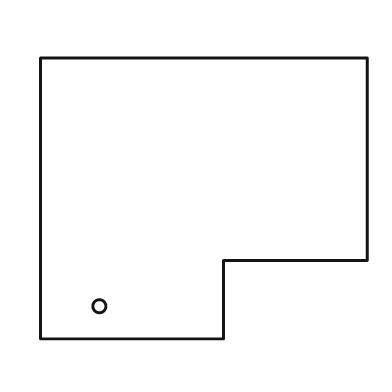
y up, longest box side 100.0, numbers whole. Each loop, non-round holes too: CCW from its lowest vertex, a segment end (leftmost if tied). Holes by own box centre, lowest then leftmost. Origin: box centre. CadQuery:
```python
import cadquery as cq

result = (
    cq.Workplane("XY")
    .moveTo(-50.0, -43.0)
    .lineTo(6.0, -43.0)
    .lineTo(6.0, -19.0)
    .lineTo(50.0, -19.0)
    .lineTo(50.0, 43.0)
    .lineTo(-50.0, 43.0)
    .close()
    .moveTo(-32.0, -33.0)
    .circle(2.0)
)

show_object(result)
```